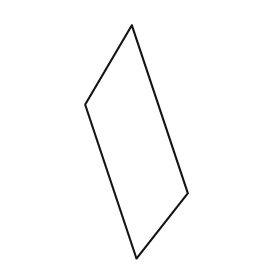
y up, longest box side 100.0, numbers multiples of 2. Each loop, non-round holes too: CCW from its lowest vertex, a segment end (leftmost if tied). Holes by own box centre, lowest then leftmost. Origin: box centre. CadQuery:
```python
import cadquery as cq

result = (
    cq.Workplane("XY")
    .moveTo(0.0, -50.0)
    .lineTo(22.0, -22.0)
    .lineTo(-2.0, 50.0)
    .lineTo(-22.0, 16.0)
    .close()
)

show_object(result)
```